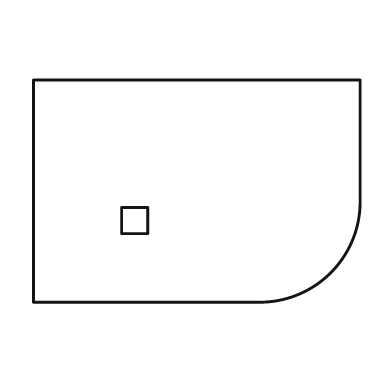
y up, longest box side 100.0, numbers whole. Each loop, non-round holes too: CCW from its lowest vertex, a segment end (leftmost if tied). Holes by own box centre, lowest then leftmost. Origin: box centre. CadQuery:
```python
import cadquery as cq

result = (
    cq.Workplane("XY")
    .moveTo(-50.0, -34.0)
    .lineTo(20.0, -34.0)
    .threePointArc((41.0, -25.0), (50.0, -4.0))
    .lineTo(50.0, 34.0)
    .lineTo(-50.0, 34.0)
    .close()
    .moveTo(-23.0, -13.0)
    .lineTo(-15.0, -13.0)
    .lineTo(-15.0, -5.0)
    .lineTo(-23.0, -5.0)
    .close()
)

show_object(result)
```